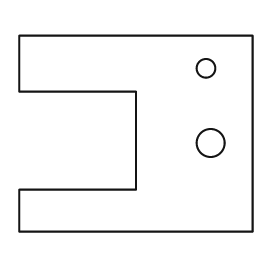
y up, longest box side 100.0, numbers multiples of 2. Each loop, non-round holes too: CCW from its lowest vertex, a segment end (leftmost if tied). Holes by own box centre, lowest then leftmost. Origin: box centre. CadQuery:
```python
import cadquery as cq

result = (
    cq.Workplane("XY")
    .moveTo(-50.0, -42.0)
    .lineTo(50.0, -42.0)
    .lineTo(50.0, 42.0)
    .lineTo(-50.0, 42.0)
    .lineTo(-50.0, 18.0)
    .lineTo(0.0, 18.0)
    .lineTo(0.0, -24.0)
    .lineTo(-50.0, -24.0)
    .close()
    .moveTo(32.0, -4.0)
    .circle(6.0)
    .moveTo(30.0, 28.0)
    .circle(4.0)
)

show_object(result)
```